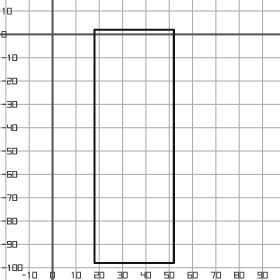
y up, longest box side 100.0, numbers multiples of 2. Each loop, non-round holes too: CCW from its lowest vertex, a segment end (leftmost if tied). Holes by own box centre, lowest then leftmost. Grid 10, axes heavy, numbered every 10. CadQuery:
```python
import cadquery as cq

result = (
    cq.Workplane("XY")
    .moveTo(18.0, -98.0)
    .lineTo(52.0, -98.0)
    .lineTo(52.0, 2.0)
    .lineTo(18.0, 2.0)
    .close()
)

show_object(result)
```